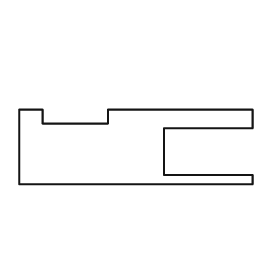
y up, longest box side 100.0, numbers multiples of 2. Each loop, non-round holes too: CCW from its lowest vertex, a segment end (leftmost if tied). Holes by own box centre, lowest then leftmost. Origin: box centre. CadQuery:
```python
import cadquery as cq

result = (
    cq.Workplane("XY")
    .moveTo(-50.0, -16.0)
    .lineTo(50.0, -16.0)
    .lineTo(50.0, -12.0)
    .lineTo(12.0, -12.0)
    .lineTo(12.0, 8.0)
    .lineTo(50.0, 8.0)
    .lineTo(50.0, 16.0)
    .lineTo(-12.0, 16.0)
    .lineTo(-12.0, 10.0)
    .lineTo(-40.0, 10.0)
    .lineTo(-40.0, 16.0)
    .lineTo(-50.0, 16.0)
    .close()
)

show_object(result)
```